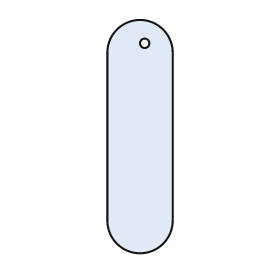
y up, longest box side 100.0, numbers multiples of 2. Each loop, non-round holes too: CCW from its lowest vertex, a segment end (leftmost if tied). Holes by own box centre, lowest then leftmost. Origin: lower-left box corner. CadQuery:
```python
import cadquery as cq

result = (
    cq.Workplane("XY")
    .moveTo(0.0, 14.0)
    .threePointArc((14.0, 0.0), (28.0, 14.0))
    .lineTo(28.0, 86.0)
    .threePointArc((14.0, 100.0), (0.0, 86.0))
    .close()
    .moveTo(16.0, 90.0)
    .circle(2.0)
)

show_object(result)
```